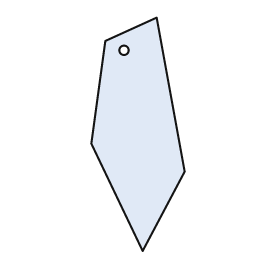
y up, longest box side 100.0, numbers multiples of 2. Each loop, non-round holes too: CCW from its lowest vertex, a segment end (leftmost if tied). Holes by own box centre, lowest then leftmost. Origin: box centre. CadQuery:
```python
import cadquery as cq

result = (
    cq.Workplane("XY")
    .moveTo(2.0, -50.0)
    .lineTo(20.0, -16.0)
    .lineTo(8.0, 50.0)
    .lineTo(-14.0, 40.0)
    .lineTo(-20.0, -4.0)
    .close()
    .moveTo(-6.0, 36.0)
    .circle(2.0)
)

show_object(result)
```